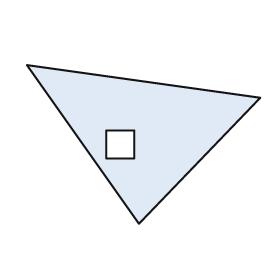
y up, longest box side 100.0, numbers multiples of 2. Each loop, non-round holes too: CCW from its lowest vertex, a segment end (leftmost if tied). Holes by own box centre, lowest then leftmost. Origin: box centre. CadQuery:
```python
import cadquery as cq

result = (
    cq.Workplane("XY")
    .moveTo(-2.0, -34.0)
    .lineTo(50.0, 20.0)
    .lineTo(-50.0, 34.0)
    .close()
    .moveTo(-16.0, -6.0)
    .lineTo(-4.0, -6.0)
    .lineTo(-4.0, 6.0)
    .lineTo(-16.0, 6.0)
    .close()
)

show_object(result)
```